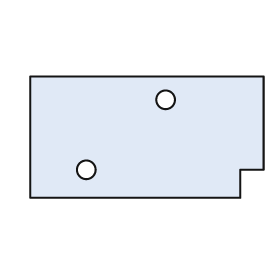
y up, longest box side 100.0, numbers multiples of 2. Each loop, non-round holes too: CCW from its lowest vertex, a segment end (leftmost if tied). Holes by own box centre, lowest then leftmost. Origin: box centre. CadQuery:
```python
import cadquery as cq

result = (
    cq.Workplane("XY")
    .moveTo(-50.0, -26.0)
    .lineTo(40.0, -26.0)
    .lineTo(40.0, -14.0)
    .lineTo(50.0, -14.0)
    .lineTo(50.0, 26.0)
    .lineTo(-50.0, 26.0)
    .close()
    .moveTo(-26.0, -14.0)
    .circle(4.0)
    .moveTo(8.0, 16.0)
    .circle(4.0)
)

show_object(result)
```